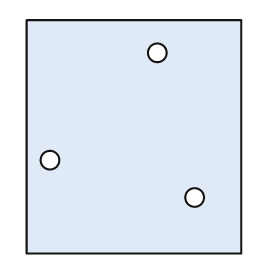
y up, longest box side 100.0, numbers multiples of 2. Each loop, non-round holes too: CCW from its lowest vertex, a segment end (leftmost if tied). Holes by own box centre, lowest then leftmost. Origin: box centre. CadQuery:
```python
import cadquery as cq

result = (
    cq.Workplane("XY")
    .moveTo(-46.0, -50.0)
    .lineTo(46.0, -50.0)
    .lineTo(46.0, 50.0)
    .lineTo(-46.0, 50.0)
    .close()
    .moveTo(26.0, -26.0)
    .circle(4.0)
    .moveTo(-36.0, -10.0)
    .circle(4.0)
    .moveTo(10.0, 36.0)
    .circle(4.0)
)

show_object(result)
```